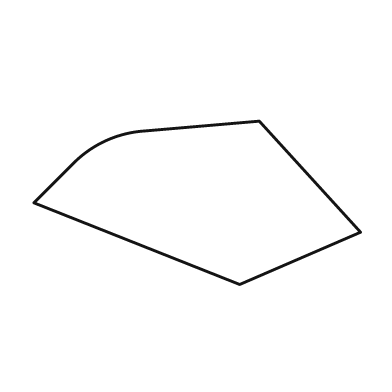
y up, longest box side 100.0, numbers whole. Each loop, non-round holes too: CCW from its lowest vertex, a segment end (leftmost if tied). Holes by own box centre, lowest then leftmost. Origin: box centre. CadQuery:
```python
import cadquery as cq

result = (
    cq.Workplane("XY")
    .moveTo(13.0, -25.0)
    .lineTo(50.0, -9.0)
    .lineTo(19.0, 25.0)
    .lineTo(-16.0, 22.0)
    .threePointArc((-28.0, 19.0), (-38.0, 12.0))
    .lineTo(-50.0, 0.0)
    .close()
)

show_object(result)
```